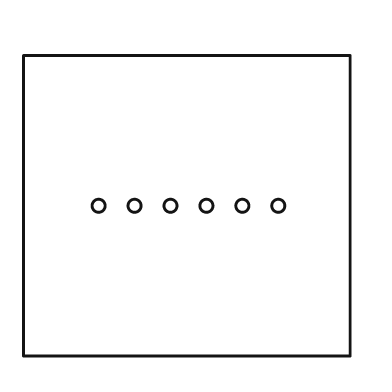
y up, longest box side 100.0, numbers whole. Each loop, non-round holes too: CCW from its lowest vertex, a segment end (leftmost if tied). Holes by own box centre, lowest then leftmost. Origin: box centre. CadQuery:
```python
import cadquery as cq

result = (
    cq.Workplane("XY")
    .moveTo(-50.0, -46.0)
    .lineTo(50.0, -46.0)
    .lineTo(50.0, 46.0)
    .lineTo(-50.0, 46.0)
    .close()
    .moveTo(-27.0, 0.0)
    .circle(2.0)
    .moveTo(-16.0, 0.0)
    .circle(2.0)
    .moveTo(-5.0, 0.0)
    .circle(2.0)
    .moveTo(6.0, 0.0)
    .circle(2.0)
    .moveTo(17.0, 0.0)
    .circle(2.0)
    .moveTo(28.0, 0.0)
    .circle(2.0)
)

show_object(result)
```